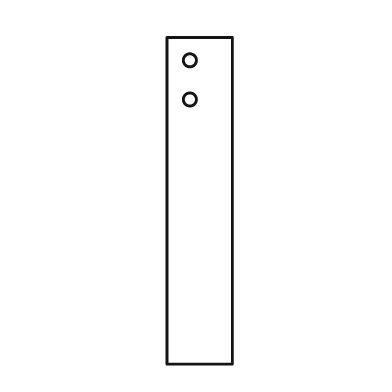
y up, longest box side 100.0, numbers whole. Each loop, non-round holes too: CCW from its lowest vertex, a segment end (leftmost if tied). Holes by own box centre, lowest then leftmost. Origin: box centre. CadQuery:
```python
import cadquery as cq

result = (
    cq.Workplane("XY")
    .moveTo(-10.0, -50.0)
    .lineTo(10.0, -50.0)
    .lineTo(10.0, 50.0)
    .lineTo(-10.0, 50.0)
    .close()
    .moveTo(-3.0, 31.0)
    .circle(2.0)
    .moveTo(-3.0, 43.0)
    .circle(2.0)
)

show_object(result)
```